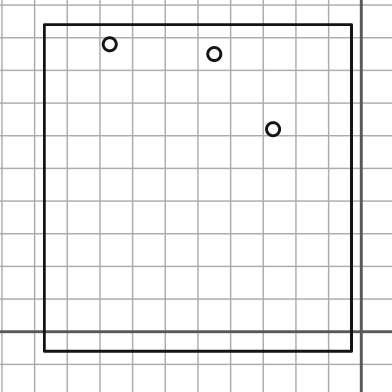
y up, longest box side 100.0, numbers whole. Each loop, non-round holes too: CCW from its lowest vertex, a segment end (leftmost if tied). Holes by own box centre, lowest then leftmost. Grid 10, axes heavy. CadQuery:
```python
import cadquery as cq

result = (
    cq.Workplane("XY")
    .moveTo(-97.0, -6.0)
    .lineTo(-3.0, -6.0)
    .lineTo(-3.0, 94.0)
    .lineTo(-97.0, 94.0)
    .close()
    .moveTo(-27.0, 62.0)
    .circle(2.0)
    .moveTo(-45.0, 85.0)
    .circle(2.0)
    .moveTo(-77.0, 88.0)
    .circle(2.0)
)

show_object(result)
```